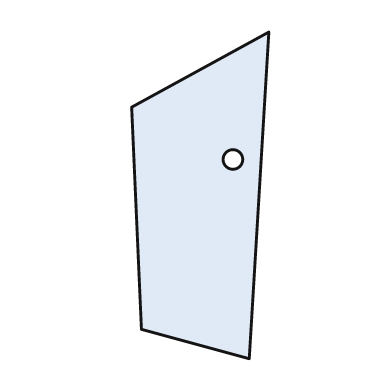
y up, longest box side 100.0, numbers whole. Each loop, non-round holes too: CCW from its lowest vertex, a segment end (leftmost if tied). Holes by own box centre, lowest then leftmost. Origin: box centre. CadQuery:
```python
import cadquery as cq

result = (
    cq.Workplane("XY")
    .moveTo(15.0, -50.0)
    .lineTo(21.0, 50.0)
    .lineTo(-21.0, 27.0)
    .lineTo(-18.0, -41.0)
    .close()
    .moveTo(10.0, 11.0)
    .circle(3.0)
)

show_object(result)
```